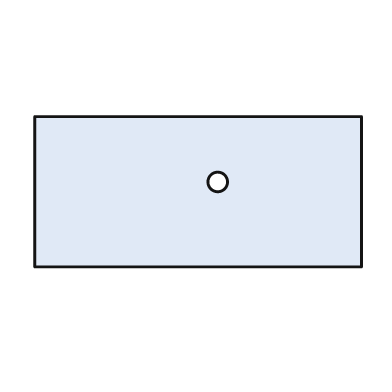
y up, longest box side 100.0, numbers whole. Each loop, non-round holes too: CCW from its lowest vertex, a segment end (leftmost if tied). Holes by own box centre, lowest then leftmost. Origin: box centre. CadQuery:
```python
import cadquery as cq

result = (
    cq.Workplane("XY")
    .moveTo(-50.0, -23.0)
    .lineTo(50.0, -23.0)
    .lineTo(50.0, 23.0)
    .lineTo(-50.0, 23.0)
    .close()
    .moveTo(6.0, 3.0)
    .circle(3.0)
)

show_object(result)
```